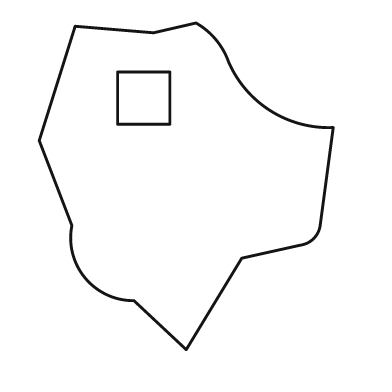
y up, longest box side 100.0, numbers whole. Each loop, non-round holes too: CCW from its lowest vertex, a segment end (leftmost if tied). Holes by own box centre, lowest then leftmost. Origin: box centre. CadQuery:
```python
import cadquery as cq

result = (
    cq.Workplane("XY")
    .moveTo(0.0, -50.0)
    .lineTo(17.0, -22.0)
    .lineTo(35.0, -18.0)
    .threePointArc((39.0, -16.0), (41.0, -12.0))
    .lineTo(45.0, 18.0)
    .threePointArc((26.0, 23.0), (13.0, 38.0))
    .threePointArc((9.0, 45.0), (3.0, 50.0))
    .lineTo(-10.0, 47.0)
    .lineTo(-34.0, 49.0)
    .lineTo(-45.0, 14.0)
    .lineTo(-35.0, -12.0)
    .threePointArc((-31.0, -28.0), (-16.0, -35.0))
    .close()
    .moveTo(-21.0, 19.0)
    .lineTo(-5.0, 19.0)
    .lineTo(-5.0, 35.0)
    .lineTo(-21.0, 35.0)
    .close()
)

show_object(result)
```